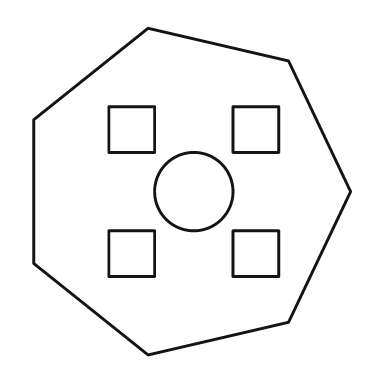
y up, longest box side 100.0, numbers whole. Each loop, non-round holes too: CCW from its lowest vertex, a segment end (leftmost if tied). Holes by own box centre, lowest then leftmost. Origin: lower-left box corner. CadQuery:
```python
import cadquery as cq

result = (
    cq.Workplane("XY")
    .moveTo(35.0, 0.0)
    .lineTo(78.0, 10.0)
    .lineTo(97.0, 50.0)
    .lineTo(78.0, 90.0)
    .lineTo(35.0, 100.0)
    .lineTo(0.0, 72.0)
    .lineTo(0.0, 28.0)
    .close()
    .moveTo(23.0, 24.0)
    .lineTo(37.0, 24.0)
    .lineTo(37.0, 38.0)
    .lineTo(23.0, 38.0)
    .close()
    .moveTo(61.0, 24.0)
    .lineTo(75.0, 24.0)
    .lineTo(75.0, 38.0)
    .lineTo(61.0, 38.0)
    .close()
    .moveTo(49.0, 50.0)
    .circle(12.0)
    .moveTo(23.0, 62.0)
    .lineTo(37.0, 62.0)
    .lineTo(37.0, 76.0)
    .lineTo(23.0, 76.0)
    .close()
    .moveTo(61.0, 62.0)
    .lineTo(75.0, 62.0)
    .lineTo(75.0, 76.0)
    .lineTo(61.0, 76.0)
    .close()
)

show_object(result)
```